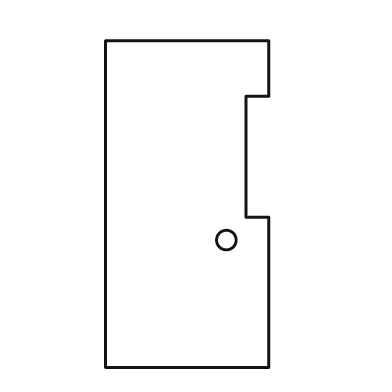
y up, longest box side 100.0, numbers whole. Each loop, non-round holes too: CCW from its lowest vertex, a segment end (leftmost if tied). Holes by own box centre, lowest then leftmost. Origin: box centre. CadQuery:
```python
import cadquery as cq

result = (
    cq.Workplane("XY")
    .moveTo(-25.0, -50.0)
    .lineTo(25.0, -50.0)
    .lineTo(25.0, -4.0)
    .lineTo(18.0, -4.0)
    .lineTo(18.0, 33.0)
    .lineTo(25.0, 33.0)
    .lineTo(25.0, 50.0)
    .lineTo(-25.0, 50.0)
    .close()
    .moveTo(12.0, -11.0)
    .circle(3.0)
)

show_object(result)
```